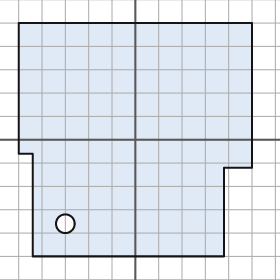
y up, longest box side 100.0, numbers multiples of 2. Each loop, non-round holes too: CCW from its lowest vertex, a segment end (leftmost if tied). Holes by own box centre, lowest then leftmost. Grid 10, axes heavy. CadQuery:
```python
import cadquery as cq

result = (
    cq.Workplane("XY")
    .moveTo(-44.0, -50.0)
    .lineTo(38.0, -50.0)
    .lineTo(38.0, -12.0)
    .lineTo(50.0, -12.0)
    .lineTo(50.0, 50.0)
    .lineTo(-50.0, 50.0)
    .lineTo(-50.0, -6.0)
    .lineTo(-44.0, -6.0)
    .close()
    .moveTo(-30.0, -36.0)
    .circle(4.0)
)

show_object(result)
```